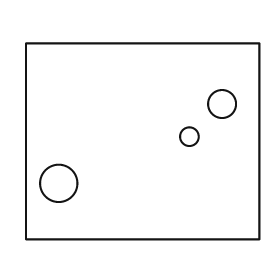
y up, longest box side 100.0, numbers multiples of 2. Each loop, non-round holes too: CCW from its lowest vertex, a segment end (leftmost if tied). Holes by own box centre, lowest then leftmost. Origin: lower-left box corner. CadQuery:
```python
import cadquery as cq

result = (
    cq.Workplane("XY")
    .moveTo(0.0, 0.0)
    .lineTo(100.0, 0.0)
    .lineTo(100.0, 84.0)
    .lineTo(0.0, 84.0)
    .close()
    .moveTo(14.0, 24.0)
    .circle(8.0)
    .moveTo(70.0, 44.0)
    .circle(4.0)
    .moveTo(84.0, 58.0)
    .circle(6.0)
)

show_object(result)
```